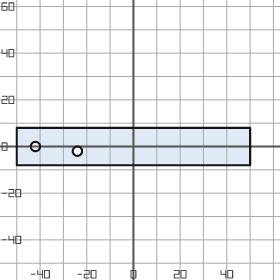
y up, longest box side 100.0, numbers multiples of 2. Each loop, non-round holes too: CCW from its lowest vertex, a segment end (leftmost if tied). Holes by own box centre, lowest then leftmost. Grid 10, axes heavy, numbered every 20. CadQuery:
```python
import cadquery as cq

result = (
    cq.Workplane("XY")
    .moveTo(-50.0, -8.0)
    .lineTo(50.0, -8.0)
    .lineTo(50.0, 8.0)
    .lineTo(-50.0, 8.0)
    .close()
    .moveTo(-24.0, -2.0)
    .circle(2.0)
    .moveTo(-42.0, 0.0)
    .circle(2.0)
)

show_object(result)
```